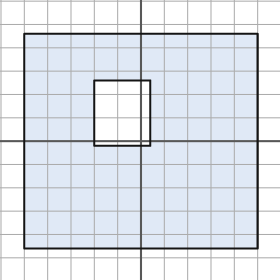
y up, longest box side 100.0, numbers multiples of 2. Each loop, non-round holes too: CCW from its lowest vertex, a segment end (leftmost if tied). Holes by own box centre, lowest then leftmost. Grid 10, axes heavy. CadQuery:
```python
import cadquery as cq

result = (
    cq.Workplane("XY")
    .moveTo(-50.0, -46.0)
    .lineTo(50.0, -46.0)
    .lineTo(50.0, 46.0)
    .lineTo(-50.0, 46.0)
    .close()
    .moveTo(-20.0, -2.0)
    .lineTo(4.0, -2.0)
    .lineTo(4.0, 26.0)
    .lineTo(-20.0, 26.0)
    .close()
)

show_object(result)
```